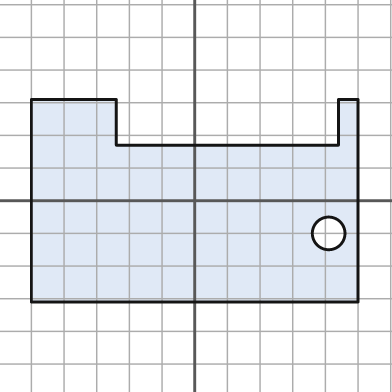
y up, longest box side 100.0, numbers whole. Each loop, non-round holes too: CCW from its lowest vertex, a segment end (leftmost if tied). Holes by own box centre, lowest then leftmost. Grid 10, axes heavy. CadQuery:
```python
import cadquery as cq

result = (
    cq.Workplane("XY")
    .moveTo(-50.0, -31.0)
    .lineTo(50.0, -31.0)
    .lineTo(50.0, 31.0)
    .lineTo(44.0, 31.0)
    .lineTo(44.0, 17.0)
    .lineTo(-24.0, 17.0)
    .lineTo(-24.0, 31.0)
    .lineTo(-50.0, 31.0)
    .close()
    .moveTo(41.0, -10.0)
    .circle(5.0)
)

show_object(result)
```